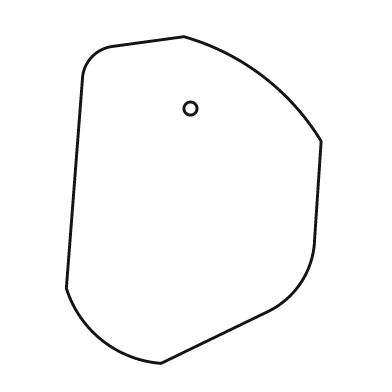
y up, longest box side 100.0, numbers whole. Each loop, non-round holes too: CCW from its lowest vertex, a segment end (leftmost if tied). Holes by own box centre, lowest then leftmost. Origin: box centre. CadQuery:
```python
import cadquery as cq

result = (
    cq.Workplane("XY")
    .moveTo(-10.0, -50.0)
    .lineTo(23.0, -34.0)
    .threePointArc((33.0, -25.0), (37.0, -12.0))
    .lineTo(39.0, 18.0)
    .threePointArc((21.0, 38.0), (-3.0, 50.0))
    .lineTo(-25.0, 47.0)
    .threePointArc((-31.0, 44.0), (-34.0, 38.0))
    .lineTo(-39.0, -27.0)
    .threePointArc((-28.0, -43.0), (-10.0, -50.0))
    .close()
    .moveTo(-1.0, 28.0)
    .circle(2.0)
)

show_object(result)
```